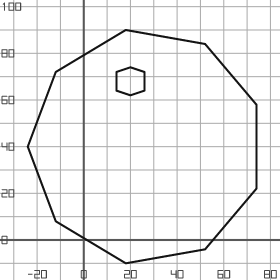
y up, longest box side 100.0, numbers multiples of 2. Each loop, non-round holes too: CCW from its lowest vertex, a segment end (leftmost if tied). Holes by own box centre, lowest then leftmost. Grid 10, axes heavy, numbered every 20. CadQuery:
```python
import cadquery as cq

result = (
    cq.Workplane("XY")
    .moveTo(18.0, -10.0)
    .lineTo(52.0, -4.0)
    .lineTo(74.0, 22.0)
    .lineTo(74.0, 58.0)
    .lineTo(52.0, 84.0)
    .lineTo(18.0, 90.0)
    .lineTo(-12.0, 72.0)
    .lineTo(-24.0, 40.0)
    .lineTo(-12.0, 8.0)
    .close()
    .moveTo(20.0, 62.0)
    .lineTo(26.0, 64.0)
    .lineTo(26.0, 72.0)
    .lineTo(20.0, 74.0)
    .lineTo(14.0, 72.0)
    .lineTo(14.0, 64.0)
    .close()
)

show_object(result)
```